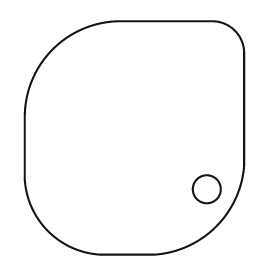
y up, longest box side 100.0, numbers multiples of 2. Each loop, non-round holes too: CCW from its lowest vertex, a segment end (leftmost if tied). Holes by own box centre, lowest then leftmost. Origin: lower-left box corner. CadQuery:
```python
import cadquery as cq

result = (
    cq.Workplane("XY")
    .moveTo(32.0, 0.0)
    .lineTo(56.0, 0.0)
    .threePointArc((82.0, 12.0), (94.0, 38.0))
    .lineTo(94.0, 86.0)
    .threePointArc((90.0, 96.0), (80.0, 100.0))
    .lineTo(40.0, 100.0)
    .threePointArc((12.0, 88.0), (0.0, 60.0))
    .lineTo(0.0, 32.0)
    .threePointArc((10.0, 10.0), (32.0, 0.0))
    .close()
    .moveTo(78.0, 28.0)
    .circle(6.0)
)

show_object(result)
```